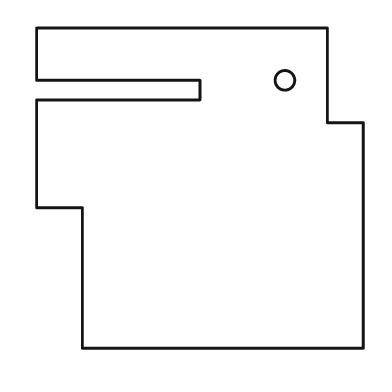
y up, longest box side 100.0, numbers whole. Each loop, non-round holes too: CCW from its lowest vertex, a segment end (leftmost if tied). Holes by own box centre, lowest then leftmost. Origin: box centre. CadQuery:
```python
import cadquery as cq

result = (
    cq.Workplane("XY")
    .moveTo(-36.0, -49.0)
    .lineTo(50.0, -49.0)
    .lineTo(50.0, 20.0)
    .lineTo(39.0, 20.0)
    .lineTo(39.0, 49.0)
    .lineTo(-50.0, 49.0)
    .lineTo(-50.0, 33.0)
    .lineTo(0.0, 33.0)
    .lineTo(0.0, 27.0)
    .lineTo(-50.0, 27.0)
    .lineTo(-50.0, -6.0)
    .lineTo(-36.0, -6.0)
    .close()
    .moveTo(26.0, 33.0)
    .circle(3.0)
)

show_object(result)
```